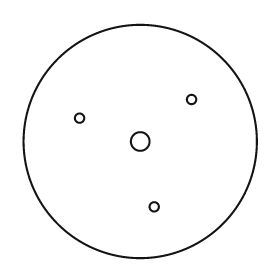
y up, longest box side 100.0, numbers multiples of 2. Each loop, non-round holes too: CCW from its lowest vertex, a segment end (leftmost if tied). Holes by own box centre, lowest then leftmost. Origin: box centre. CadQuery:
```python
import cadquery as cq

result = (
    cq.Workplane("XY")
    .moveTo(0.0, 0.0)
    .circle(50.0)
    .moveTo(6.0, -28.0)
    .circle(2.0)
    .moveTo(0.0, 0.0)
    .circle(4.0)
    .moveTo(-26.0, 10.0)
    .circle(2.0)
    .moveTo(22.0, 18.0)
    .circle(2.0)
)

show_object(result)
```